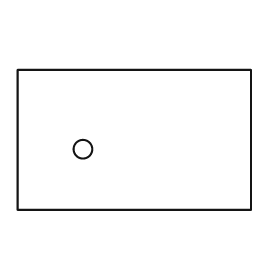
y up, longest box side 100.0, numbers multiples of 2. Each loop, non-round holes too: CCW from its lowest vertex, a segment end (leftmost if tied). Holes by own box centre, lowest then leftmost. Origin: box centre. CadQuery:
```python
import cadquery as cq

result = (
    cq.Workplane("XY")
    .moveTo(-50.0, -30.0)
    .lineTo(50.0, -30.0)
    .lineTo(50.0, 30.0)
    .lineTo(-50.0, 30.0)
    .close()
    .moveTo(-22.0, -4.0)
    .circle(4.0)
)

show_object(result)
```